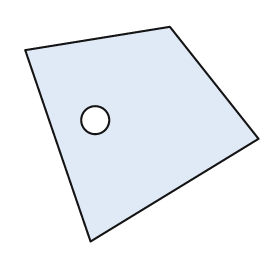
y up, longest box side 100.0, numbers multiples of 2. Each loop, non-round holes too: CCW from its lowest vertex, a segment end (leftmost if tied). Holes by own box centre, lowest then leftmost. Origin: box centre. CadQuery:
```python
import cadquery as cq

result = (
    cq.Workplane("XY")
    .moveTo(-22.0, -46.0)
    .lineTo(50.0, -2.0)
    .lineTo(12.0, 46.0)
    .lineTo(-50.0, 36.0)
    .close()
    .moveTo(-20.0, 6.0)
    .circle(6.0)
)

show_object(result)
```